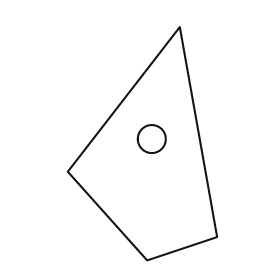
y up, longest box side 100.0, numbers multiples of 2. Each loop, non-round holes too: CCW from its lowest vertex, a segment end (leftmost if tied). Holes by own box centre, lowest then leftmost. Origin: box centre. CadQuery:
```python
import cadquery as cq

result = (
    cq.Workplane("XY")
    .moveTo(2.0, -50.0)
    .lineTo(32.0, -40.0)
    .lineTo(16.0, 50.0)
    .lineTo(-32.0, -12.0)
    .close()
    .moveTo(4.0, 2.0)
    .circle(6.0)
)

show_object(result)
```